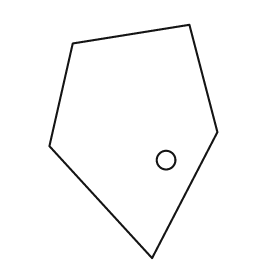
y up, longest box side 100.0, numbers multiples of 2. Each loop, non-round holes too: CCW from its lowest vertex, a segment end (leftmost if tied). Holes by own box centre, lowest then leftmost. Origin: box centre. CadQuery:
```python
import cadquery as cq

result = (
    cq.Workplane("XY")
    .moveTo(8.0, -50.0)
    .lineTo(36.0, 4.0)
    .lineTo(24.0, 50.0)
    .lineTo(-26.0, 42.0)
    .lineTo(-36.0, -2.0)
    .close()
    .moveTo(14.0, -8.0)
    .circle(4.0)
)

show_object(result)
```